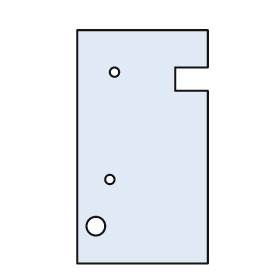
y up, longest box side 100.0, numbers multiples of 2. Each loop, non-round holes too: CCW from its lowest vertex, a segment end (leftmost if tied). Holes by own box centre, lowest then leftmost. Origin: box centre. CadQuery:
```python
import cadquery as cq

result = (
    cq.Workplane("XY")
    .moveTo(-28.0, -50.0)
    .lineTo(28.0, -50.0)
    .lineTo(28.0, 24.0)
    .lineTo(14.0, 24.0)
    .lineTo(14.0, 34.0)
    .lineTo(28.0, 34.0)
    .lineTo(28.0, 50.0)
    .lineTo(-28.0, 50.0)
    .close()
    .moveTo(-20.0, -34.0)
    .circle(4.0)
    .moveTo(-14.0, -14.0)
    .circle(2.0)
    .moveTo(-12.0, 32.0)
    .circle(2.0)
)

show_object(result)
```